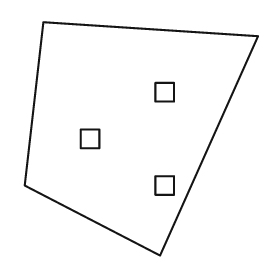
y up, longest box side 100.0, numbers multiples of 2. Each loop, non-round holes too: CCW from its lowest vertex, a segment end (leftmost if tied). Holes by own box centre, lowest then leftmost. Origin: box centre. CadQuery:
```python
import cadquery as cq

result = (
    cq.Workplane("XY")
    .moveTo(8.0, -50.0)
    .lineTo(50.0, 44.0)
    .lineTo(-42.0, 50.0)
    .lineTo(-50.0, -20.0)
    .close()
    .moveTo(6.0, -24.0)
    .lineTo(14.0, -24.0)
    .lineTo(14.0, -16.0)
    .lineTo(6.0, -16.0)
    .close()
    .moveTo(-26.0, -4.0)
    .lineTo(-18.0, -4.0)
    .lineTo(-18.0, 4.0)
    .lineTo(-26.0, 4.0)
    .close()
    .moveTo(6.0, 16.0)
    .lineTo(14.0, 16.0)
    .lineTo(14.0, 24.0)
    .lineTo(6.0, 24.0)
    .close()
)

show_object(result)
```